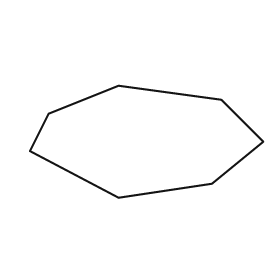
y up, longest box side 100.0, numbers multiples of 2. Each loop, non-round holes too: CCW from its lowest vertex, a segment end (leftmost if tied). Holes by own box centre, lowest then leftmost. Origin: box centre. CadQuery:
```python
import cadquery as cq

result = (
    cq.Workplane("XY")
    .moveTo(-12.0, -24.0)
    .lineTo(28.0, -18.0)
    .lineTo(50.0, 0.0)
    .lineTo(32.0, 18.0)
    .lineTo(-12.0, 24.0)
    .lineTo(-42.0, 12.0)
    .lineTo(-50.0, -4.0)
    .close()
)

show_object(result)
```